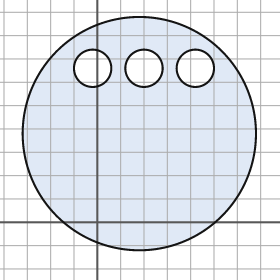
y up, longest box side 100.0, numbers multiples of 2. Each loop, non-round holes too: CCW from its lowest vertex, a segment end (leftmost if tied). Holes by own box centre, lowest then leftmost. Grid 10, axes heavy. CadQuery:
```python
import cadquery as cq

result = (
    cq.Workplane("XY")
    .moveTo(18.0, 38.0)
    .circle(50.0)
    .moveTo(-2.0, 66.0)
    .circle(8.0)
    .moveTo(20.0, 66.0)
    .circle(8.0)
    .moveTo(42.0, 66.0)
    .circle(8.0)
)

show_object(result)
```